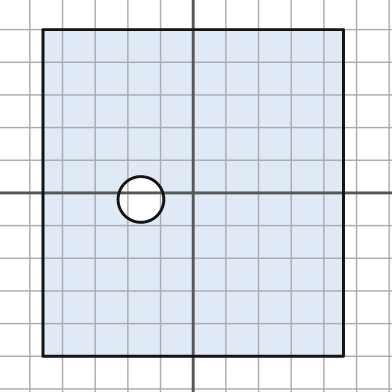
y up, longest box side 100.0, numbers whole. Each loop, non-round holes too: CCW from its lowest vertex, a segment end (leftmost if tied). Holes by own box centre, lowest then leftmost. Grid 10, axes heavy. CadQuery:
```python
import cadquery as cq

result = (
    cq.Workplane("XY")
    .moveTo(-46.0, -50.0)
    .lineTo(46.0, -50.0)
    .lineTo(46.0, 50.0)
    .lineTo(-46.0, 50.0)
    .close()
    .moveTo(-16.0, -2.0)
    .circle(7.0)
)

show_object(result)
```